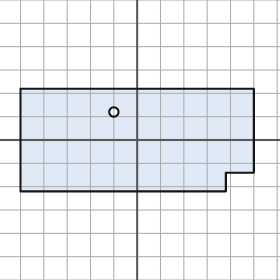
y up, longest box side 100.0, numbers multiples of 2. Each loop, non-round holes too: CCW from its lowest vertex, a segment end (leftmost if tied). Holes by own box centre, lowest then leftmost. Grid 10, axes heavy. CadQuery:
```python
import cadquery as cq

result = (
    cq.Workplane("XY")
    .moveTo(-50.0, -22.0)
    .lineTo(38.0, -22.0)
    .lineTo(38.0, -14.0)
    .lineTo(50.0, -14.0)
    .lineTo(50.0, 22.0)
    .lineTo(-50.0, 22.0)
    .close()
    .moveTo(-10.0, 12.0)
    .circle(2.0)
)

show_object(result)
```